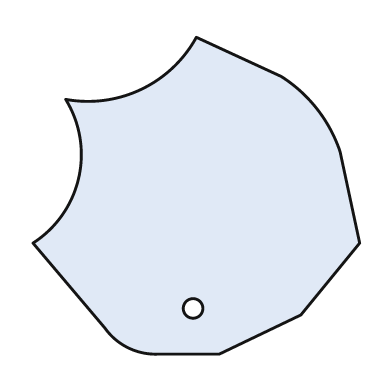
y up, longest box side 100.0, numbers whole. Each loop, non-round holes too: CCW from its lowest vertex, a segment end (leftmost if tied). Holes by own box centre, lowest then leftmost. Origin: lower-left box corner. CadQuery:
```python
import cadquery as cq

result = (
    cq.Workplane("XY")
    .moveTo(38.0, 0.0)
    .lineTo(57.0, 0.0)
    .lineTo(82.0, 12.0)
    .lineTo(100.0, 34.0)
    .lineTo(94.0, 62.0)
    .threePointArc((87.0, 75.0), (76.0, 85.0))
    .lineTo(50.0, 97.0)
    .threePointArc((33.0, 81.0), (10.0, 78.0))
    .threePointArc((14.0, 54.0), (0.0, 34.0))
    .lineTo(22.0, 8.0)
    .threePointArc((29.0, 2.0), (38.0, 0.0))
    .close()
    .moveTo(49.0, 14.0)
    .circle(3.0)
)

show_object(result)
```